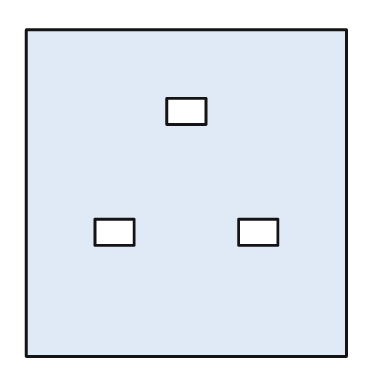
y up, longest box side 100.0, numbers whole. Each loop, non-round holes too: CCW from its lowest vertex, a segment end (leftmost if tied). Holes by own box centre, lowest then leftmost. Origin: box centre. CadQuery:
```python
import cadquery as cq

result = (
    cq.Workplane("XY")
    .moveTo(-49.0, -50.0)
    .lineTo(49.0, -50.0)
    .lineTo(49.0, 50.0)
    .lineTo(-49.0, 50.0)
    .close()
    .moveTo(-28.0, -16.0)
    .lineTo(-16.0, -16.0)
    .lineTo(-16.0, -8.0)
    .lineTo(-28.0, -8.0)
    .close()
    .moveTo(16.0, -16.0)
    .lineTo(28.0, -16.0)
    .lineTo(28.0, -8.0)
    .lineTo(16.0, -8.0)
    .close()
    .moveTo(-6.0, 21.0)
    .lineTo(6.0, 21.0)
    .lineTo(6.0, 29.0)
    .lineTo(-6.0, 29.0)
    .close()
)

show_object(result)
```